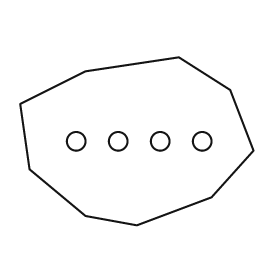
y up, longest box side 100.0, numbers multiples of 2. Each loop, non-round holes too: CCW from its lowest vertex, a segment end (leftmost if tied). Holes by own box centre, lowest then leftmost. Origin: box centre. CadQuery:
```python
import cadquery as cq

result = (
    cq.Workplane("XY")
    .moveTo(0.0, -36.0)
    .lineTo(32.0, -24.0)
    .lineTo(50.0, -4.0)
    .lineTo(40.0, 22.0)
    .lineTo(18.0, 36.0)
    .lineTo(-22.0, 30.0)
    .lineTo(-50.0, 16.0)
    .lineTo(-46.0, -12.0)
    .lineTo(-22.0, -32.0)
    .close()
    .moveTo(-26.0, 0.0)
    .circle(4.0)
    .moveTo(-8.0, 0.0)
    .circle(4.0)
    .moveTo(10.0, 0.0)
    .circle(4.0)
    .moveTo(28.0, 0.0)
    .circle(4.0)
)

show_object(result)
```